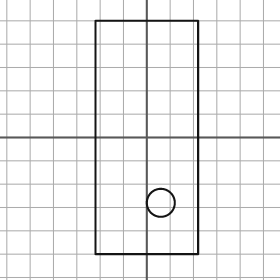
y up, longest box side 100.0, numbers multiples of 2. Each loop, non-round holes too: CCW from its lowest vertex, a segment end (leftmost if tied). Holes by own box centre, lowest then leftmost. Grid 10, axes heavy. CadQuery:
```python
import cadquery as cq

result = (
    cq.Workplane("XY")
    .moveTo(-22.0, -50.0)
    .lineTo(22.0, -50.0)
    .lineTo(22.0, 50.0)
    .lineTo(-22.0, 50.0)
    .close()
    .moveTo(6.0, -28.0)
    .circle(6.0)
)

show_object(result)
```